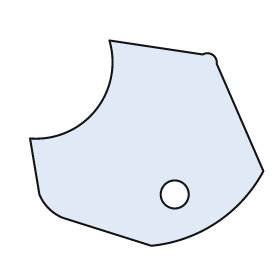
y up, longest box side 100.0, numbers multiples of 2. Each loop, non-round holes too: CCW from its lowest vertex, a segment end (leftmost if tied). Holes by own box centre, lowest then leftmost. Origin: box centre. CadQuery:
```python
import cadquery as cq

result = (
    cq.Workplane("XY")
    .moveTo(2.0, -44.0)
    .threePointArc((30.0, -34.0), (50.0, -12.0))
    .lineTo(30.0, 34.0)
    .threePointArc((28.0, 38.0), (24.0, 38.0))
    .lineTo(-16.0, 44.0)
    .threePointArc((-22.0, 14.0), (-50.0, 2.0))
    .lineTo(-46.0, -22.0)
    .threePointArc((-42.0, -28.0), (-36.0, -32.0))
    .close()
    .moveTo(12.0, -22.0)
    .circle(6.0)
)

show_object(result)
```